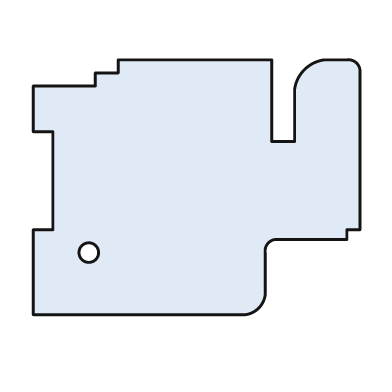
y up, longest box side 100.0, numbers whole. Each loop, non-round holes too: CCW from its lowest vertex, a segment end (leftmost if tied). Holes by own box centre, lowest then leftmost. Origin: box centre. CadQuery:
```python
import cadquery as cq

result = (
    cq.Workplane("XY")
    .moveTo(-50.0, -39.0)
    .lineTo(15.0, -39.0)
    .threePointArc((19.0, -37.0), (21.0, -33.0))
    .lineTo(21.0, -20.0)
    .threePointArc((22.0, -17.0), (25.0, -16.0))
    .lineTo(46.0, -16.0)
    .lineTo(46.0, -13.0)
    .lineTo(50.0, -13.0)
    .lineTo(50.0, 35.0)
    .threePointArc((49.0, 38.0), (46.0, 39.0))
    .lineTo(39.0, 39.0)
    .threePointArc((33.0, 36.0), (30.0, 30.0))
    .lineTo(30.0, 14.0)
    .lineTo(23.0, 14.0)
    .lineTo(23.0, 39.0)
    .lineTo(-24.0, 39.0)
    .lineTo(-24.0, 35.0)
    .lineTo(-31.0, 35.0)
    .lineTo(-31.0, 31.0)
    .lineTo(-50.0, 31.0)
    .lineTo(-50.0, 17.0)
    .lineTo(-44.0, 17.0)
    .lineTo(-44.0, -13.0)
    .lineTo(-50.0, -13.0)
    .close()
    .moveTo(-33.0, -20.0)
    .circle(3.0)
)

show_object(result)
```